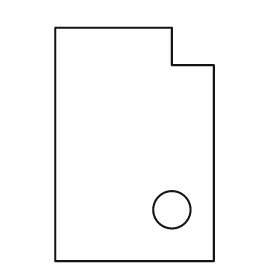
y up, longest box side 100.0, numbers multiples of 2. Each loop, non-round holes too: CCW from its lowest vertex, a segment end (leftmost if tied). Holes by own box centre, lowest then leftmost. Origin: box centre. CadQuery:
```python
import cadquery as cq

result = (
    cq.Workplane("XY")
    .moveTo(-34.0, -50.0)
    .lineTo(34.0, -50.0)
    .lineTo(34.0, 34.0)
    .lineTo(16.0, 34.0)
    .lineTo(16.0, 50.0)
    .lineTo(-34.0, 50.0)
    .close()
    .moveTo(16.0, -28.0)
    .circle(8.0)
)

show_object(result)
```